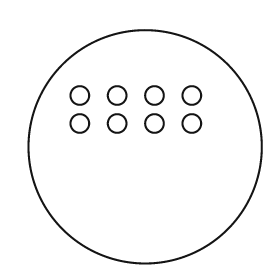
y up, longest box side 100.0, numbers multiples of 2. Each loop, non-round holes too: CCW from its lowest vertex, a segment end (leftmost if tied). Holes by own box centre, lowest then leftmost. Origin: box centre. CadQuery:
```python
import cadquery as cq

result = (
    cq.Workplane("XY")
    .moveTo(0.0, 0.0)
    .circle(50.0)
    .moveTo(-28.0, 10.0)
    .circle(4.0)
    .moveTo(-12.0, 10.0)
    .circle(4.0)
    .moveTo(4.0, 10.0)
    .circle(4.0)
    .moveTo(20.0, 10.0)
    .circle(4.0)
    .moveTo(-28.0, 22.0)
    .circle(4.0)
    .moveTo(-12.0, 22.0)
    .circle(4.0)
    .moveTo(4.0, 22.0)
    .circle(4.0)
    .moveTo(20.0, 22.0)
    .circle(4.0)
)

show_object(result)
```